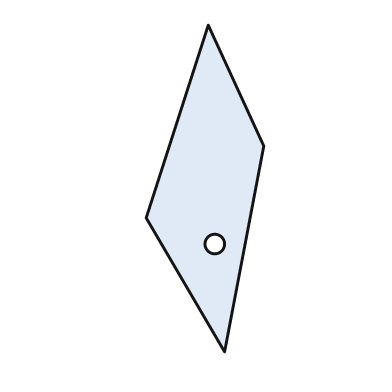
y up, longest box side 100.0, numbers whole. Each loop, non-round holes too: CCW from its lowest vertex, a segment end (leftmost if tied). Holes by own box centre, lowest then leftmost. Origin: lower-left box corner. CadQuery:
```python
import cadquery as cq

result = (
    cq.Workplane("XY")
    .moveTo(24.0, 0.0)
    .lineTo(36.0, 63.0)
    .lineTo(19.0, 100.0)
    .lineTo(0.0, 41.0)
    .close()
    .moveTo(21.0, 33.0)
    .circle(3.0)
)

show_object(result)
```